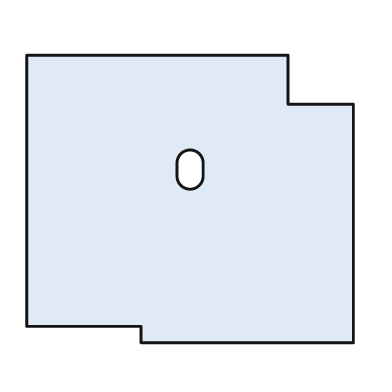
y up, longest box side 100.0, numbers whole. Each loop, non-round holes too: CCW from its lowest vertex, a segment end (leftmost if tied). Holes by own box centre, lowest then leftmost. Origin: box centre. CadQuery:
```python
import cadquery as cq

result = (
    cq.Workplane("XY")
    .moveTo(-15.0, -44.0)
    .lineTo(50.0, -44.0)
    .lineTo(50.0, 29.0)
    .lineTo(30.0, 29.0)
    .lineTo(30.0, 44.0)
    .lineTo(-50.0, 44.0)
    .lineTo(-50.0, -39.0)
    .lineTo(-15.0, -39.0)
    .close()
    .moveTo(-4.0, 7.0)
    .threePointArc((0.0, 3.0), (4.0, 7.0))
    .lineTo(4.0, 11.0)
    .threePointArc((0.0, 15.0), (-4.0, 11.0))
    .close()
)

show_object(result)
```